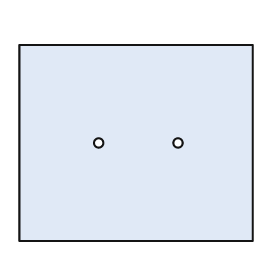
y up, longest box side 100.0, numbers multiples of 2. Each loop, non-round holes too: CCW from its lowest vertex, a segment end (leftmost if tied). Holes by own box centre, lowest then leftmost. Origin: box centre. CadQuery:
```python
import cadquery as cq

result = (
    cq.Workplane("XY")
    .moveTo(-50.0, -42.0)
    .lineTo(50.0, -42.0)
    .lineTo(50.0, 42.0)
    .lineTo(-50.0, 42.0)
    .close()
    .moveTo(-16.0, 0.0)
    .circle(2.0)
    .moveTo(18.0, 0.0)
    .circle(2.0)
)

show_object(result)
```